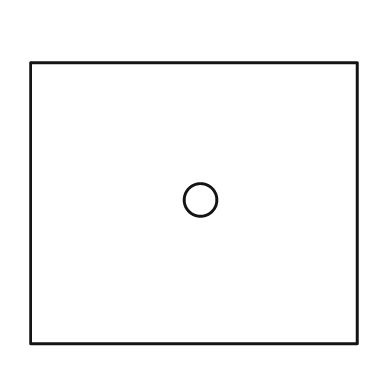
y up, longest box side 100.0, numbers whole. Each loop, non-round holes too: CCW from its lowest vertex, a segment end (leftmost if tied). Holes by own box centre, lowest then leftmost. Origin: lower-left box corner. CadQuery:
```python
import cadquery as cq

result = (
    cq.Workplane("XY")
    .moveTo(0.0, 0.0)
    .lineTo(100.0, 0.0)
    .lineTo(100.0, 86.0)
    .lineTo(0.0, 86.0)
    .close()
    .moveTo(52.0, 44.0)
    .circle(5.0)
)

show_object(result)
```